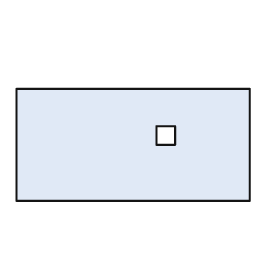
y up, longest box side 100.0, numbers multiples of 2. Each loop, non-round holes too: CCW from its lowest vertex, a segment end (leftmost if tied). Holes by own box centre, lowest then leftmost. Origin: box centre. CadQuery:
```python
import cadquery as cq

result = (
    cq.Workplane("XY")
    .moveTo(-50.0, -24.0)
    .lineTo(50.0, -24.0)
    .lineTo(50.0, 24.0)
    .lineTo(-50.0, 24.0)
    .close()
    .moveTo(10.0, 0.0)
    .lineTo(18.0, 0.0)
    .lineTo(18.0, 8.0)
    .lineTo(10.0, 8.0)
    .close()
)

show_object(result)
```